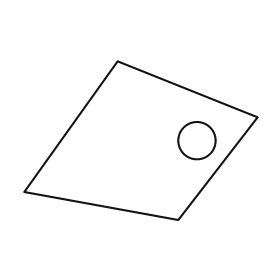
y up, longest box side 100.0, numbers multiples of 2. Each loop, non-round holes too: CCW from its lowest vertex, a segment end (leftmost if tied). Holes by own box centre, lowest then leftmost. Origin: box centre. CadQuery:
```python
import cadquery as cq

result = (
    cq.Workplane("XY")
    .moveTo(16.0, -34.0)
    .lineTo(50.0, 10.0)
    .lineTo(-10.0, 34.0)
    .lineTo(-50.0, -22.0)
    .close()
    .moveTo(24.0, 0.0)
    .circle(8.0)
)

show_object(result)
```